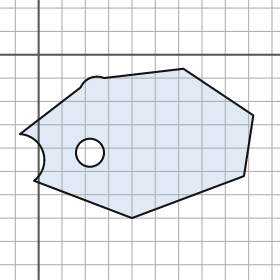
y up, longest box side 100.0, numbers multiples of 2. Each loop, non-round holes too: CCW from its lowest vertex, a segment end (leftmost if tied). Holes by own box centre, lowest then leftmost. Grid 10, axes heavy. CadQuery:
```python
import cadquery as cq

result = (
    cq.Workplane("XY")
    .moveTo(40.0, -70.0)
    .lineTo(88.0, -52.0)
    .lineTo(92.0, -26.0)
    .lineTo(62.0, -6.0)
    .lineTo(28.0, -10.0)
    .threePointArc((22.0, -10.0), (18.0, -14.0))
    .lineTo(-8.0, -34.0)
    .threePointArc((2.0, -42.0), (-2.0, -54.0))
    .close()
    .moveTo(22.0, -42.0)
    .circle(6.0)
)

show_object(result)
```